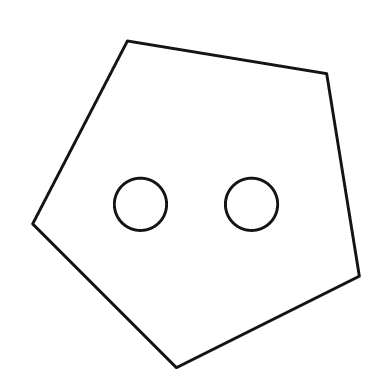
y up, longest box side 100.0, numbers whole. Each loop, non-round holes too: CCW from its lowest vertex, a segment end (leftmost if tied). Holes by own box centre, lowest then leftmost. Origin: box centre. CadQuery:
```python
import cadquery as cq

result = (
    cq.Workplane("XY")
    .moveTo(-6.0, -50.0)
    .lineTo(50.0, -22.0)
    .lineTo(40.0, 40.0)
    .lineTo(-21.0, 50.0)
    .lineTo(-50.0, -6.0)
    .close()
    .moveTo(-17.0, 0.0)
    .circle(8.0)
    .moveTo(17.0, 0.0)
    .circle(8.0)
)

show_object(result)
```